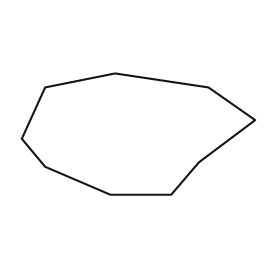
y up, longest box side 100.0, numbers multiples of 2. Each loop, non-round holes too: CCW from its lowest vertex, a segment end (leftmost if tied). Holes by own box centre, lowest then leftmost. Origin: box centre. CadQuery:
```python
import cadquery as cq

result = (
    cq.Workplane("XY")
    .moveTo(-12.0, -26.0)
    .lineTo(14.0, -26.0)
    .lineTo(26.0, -12.0)
    .lineTo(50.0, 6.0)
    .lineTo(30.0, 20.0)
    .lineTo(-10.0, 26.0)
    .lineTo(-40.0, 20.0)
    .lineTo(-50.0, -2.0)
    .lineTo(-40.0, -14.0)
    .close()
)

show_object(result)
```